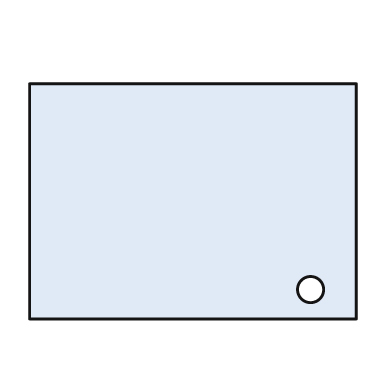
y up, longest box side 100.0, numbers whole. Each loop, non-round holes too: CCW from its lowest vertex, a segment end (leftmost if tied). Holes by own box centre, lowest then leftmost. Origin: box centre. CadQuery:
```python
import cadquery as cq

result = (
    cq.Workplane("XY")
    .moveTo(-50.0, -36.0)
    .lineTo(50.0, -36.0)
    .lineTo(50.0, 36.0)
    .lineTo(-50.0, 36.0)
    .close()
    .moveTo(36.0, -27.0)
    .circle(4.0)
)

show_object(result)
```